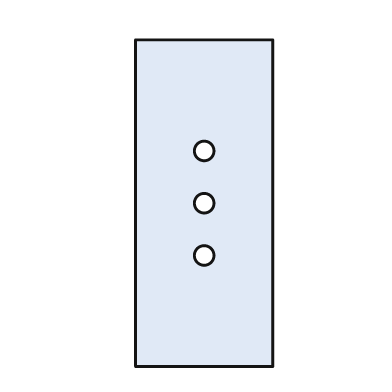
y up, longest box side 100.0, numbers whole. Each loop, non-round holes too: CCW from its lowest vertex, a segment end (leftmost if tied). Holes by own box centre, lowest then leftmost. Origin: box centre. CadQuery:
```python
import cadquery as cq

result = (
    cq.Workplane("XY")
    .moveTo(-21.0, -50.0)
    .lineTo(21.0, -50.0)
    .lineTo(21.0, 50.0)
    .lineTo(-21.0, 50.0)
    .close()
    .moveTo(0.0, -16.0)
    .circle(3.0)
    .moveTo(0.0, 0.0)
    .circle(3.0)
    .moveTo(0.0, 16.0)
    .circle(3.0)
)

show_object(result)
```